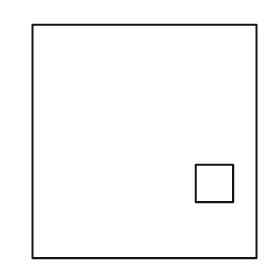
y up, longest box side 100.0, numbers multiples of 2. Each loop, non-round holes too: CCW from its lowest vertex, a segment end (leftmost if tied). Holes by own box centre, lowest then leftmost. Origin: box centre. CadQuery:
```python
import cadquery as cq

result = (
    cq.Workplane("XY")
    .moveTo(-48.0, -50.0)
    .lineTo(48.0, -50.0)
    .lineTo(48.0, 50.0)
    .lineTo(-48.0, 50.0)
    .close()
    .moveTo(22.0, -26.0)
    .lineTo(38.0, -26.0)
    .lineTo(38.0, -10.0)
    .lineTo(22.0, -10.0)
    .close()
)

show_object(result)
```